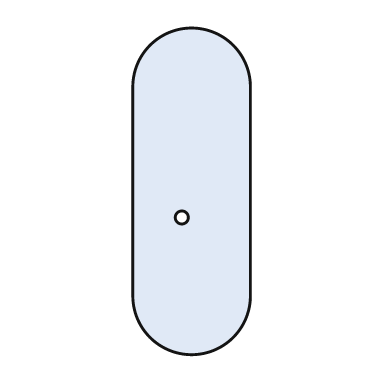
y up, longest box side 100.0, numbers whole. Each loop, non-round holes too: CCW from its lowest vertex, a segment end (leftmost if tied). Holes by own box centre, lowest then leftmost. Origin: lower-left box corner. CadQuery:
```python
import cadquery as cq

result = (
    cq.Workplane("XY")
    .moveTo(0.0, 18.0)
    .threePointArc((18.0, 0.0), (36.0, 18.0))
    .lineTo(36.0, 82.0)
    .threePointArc((18.0, 100.0), (0.0, 82.0))
    .close()
    .moveTo(15.0, 42.0)
    .circle(2.0)
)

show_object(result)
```